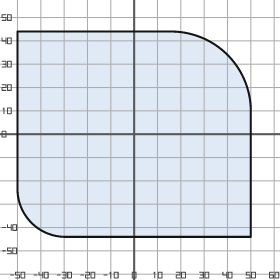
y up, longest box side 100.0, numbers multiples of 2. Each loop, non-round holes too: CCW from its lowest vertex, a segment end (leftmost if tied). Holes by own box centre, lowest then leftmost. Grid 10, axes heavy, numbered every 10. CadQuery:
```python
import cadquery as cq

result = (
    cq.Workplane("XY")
    .moveTo(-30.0, -44.0)
    .lineTo(50.0, -44.0)
    .lineTo(50.0, 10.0)
    .threePointArc((40.0, 34.0), (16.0, 44.0))
    .lineTo(-50.0, 44.0)
    .lineTo(-50.0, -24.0)
    .threePointArc((-44.0, -38.0), (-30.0, -44.0))
    .close()
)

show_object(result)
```